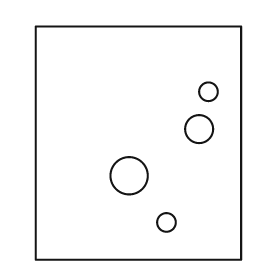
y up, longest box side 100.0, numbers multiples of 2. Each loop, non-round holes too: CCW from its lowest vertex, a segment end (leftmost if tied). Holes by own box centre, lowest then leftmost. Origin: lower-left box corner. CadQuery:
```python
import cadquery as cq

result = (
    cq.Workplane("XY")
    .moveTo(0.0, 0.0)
    .lineTo(88.0, 0.0)
    .lineTo(88.0, 100.0)
    .lineTo(0.0, 100.0)
    .close()
    .moveTo(56.0, 16.0)
    .circle(4.0)
    .moveTo(40.0, 36.0)
    .circle(8.0)
    .moveTo(70.0, 56.0)
    .circle(6.0)
    .moveTo(74.0, 72.0)
    .circle(4.0)
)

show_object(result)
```